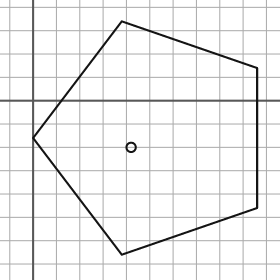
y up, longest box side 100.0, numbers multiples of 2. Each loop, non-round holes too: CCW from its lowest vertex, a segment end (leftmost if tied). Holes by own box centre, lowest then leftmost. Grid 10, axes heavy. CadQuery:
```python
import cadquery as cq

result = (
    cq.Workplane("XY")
    .moveTo(38.0, -66.0)
    .lineTo(96.0, -46.0)
    .lineTo(96.0, 14.0)
    .lineTo(38.0, 34.0)
    .lineTo(0.0, -16.0)
    .close()
    .moveTo(42.0, -20.0)
    .circle(2.0)
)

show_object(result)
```